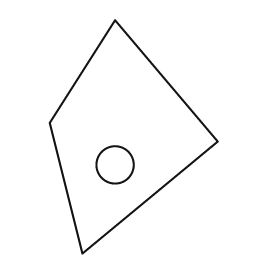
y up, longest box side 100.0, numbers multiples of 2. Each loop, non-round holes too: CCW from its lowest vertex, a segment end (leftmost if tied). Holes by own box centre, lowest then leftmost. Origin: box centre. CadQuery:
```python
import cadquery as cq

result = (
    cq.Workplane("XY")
    .moveTo(-22.0, -50.0)
    .lineTo(36.0, -2.0)
    .lineTo(-8.0, 50.0)
    .lineTo(-36.0, 6.0)
    .close()
    .moveTo(-8.0, -12.0)
    .circle(8.0)
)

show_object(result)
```